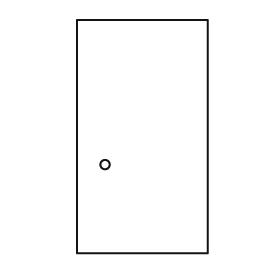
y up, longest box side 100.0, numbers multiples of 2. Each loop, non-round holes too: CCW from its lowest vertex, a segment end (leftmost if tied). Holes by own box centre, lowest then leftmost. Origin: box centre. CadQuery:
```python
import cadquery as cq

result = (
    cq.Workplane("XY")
    .moveTo(-28.0, -50.0)
    .lineTo(28.0, -50.0)
    .lineTo(28.0, 50.0)
    .lineTo(-28.0, 50.0)
    .close()
    .moveTo(-16.0, -12.0)
    .circle(2.0)
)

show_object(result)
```